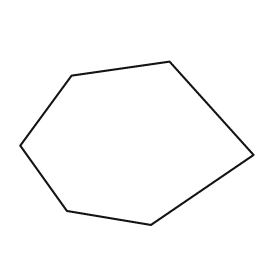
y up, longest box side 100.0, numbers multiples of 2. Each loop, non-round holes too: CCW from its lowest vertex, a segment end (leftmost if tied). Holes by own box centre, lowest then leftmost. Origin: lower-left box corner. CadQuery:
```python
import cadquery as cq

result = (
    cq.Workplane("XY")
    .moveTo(56.0, 0.0)
    .lineTo(100.0, 30.0)
    .lineTo(64.0, 70.0)
    .lineTo(22.0, 64.0)
    .lineTo(0.0, 34.0)
    .lineTo(20.0, 6.0)
    .close()
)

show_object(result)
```